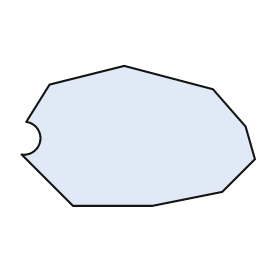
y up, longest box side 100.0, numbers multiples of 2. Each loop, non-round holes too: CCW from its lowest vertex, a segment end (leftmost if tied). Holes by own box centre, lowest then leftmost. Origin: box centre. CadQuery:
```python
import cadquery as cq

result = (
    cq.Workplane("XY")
    .moveTo(-28.0, -30.0)
    .lineTo(6.0, -30.0)
    .lineTo(36.0, -24.0)
    .lineTo(50.0, -10.0)
    .lineTo(46.0, 4.0)
    .lineTo(32.0, 20.0)
    .lineTo(-6.0, 30.0)
    .lineTo(-38.0, 22.0)
    .lineTo(-48.0, 6.0)
    .threePointArc((-42.0, -2.0), (-50.0, -8.0))
    .close()
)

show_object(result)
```